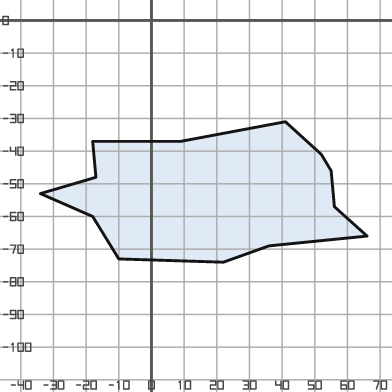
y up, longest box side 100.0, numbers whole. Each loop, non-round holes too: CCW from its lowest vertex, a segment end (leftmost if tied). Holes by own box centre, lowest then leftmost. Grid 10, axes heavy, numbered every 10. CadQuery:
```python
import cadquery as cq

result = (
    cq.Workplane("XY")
    .moveTo(22.0, -74.0)
    .lineTo(36.0, -69.0)
    .lineTo(66.0, -66.0)
    .lineTo(56.0, -57.0)
    .lineTo(55.0, -46.0)
    .lineTo(52.0, -41.0)
    .lineTo(41.0, -31.0)
    .lineTo(9.0, -37.0)
    .lineTo(-18.0, -37.0)
    .lineTo(-17.0, -48.0)
    .lineTo(-34.0, -53.0)
    .lineTo(-18.0, -60.0)
    .lineTo(-10.0, -73.0)
    .close()
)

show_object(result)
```